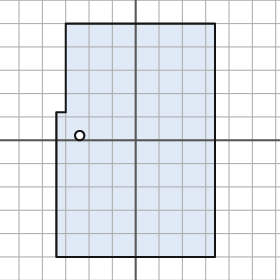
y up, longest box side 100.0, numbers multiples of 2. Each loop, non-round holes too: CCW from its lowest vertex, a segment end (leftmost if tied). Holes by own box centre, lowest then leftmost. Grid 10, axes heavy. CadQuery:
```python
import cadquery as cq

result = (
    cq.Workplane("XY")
    .moveTo(-34.0, -50.0)
    .lineTo(34.0, -50.0)
    .lineTo(34.0, 50.0)
    .lineTo(-30.0, 50.0)
    .lineTo(-30.0, 12.0)
    .lineTo(-34.0, 12.0)
    .close()
    .moveTo(-24.0, 2.0)
    .circle(2.0)
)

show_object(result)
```